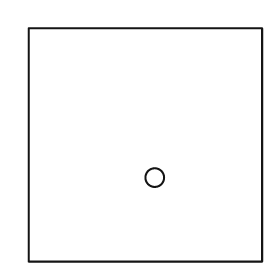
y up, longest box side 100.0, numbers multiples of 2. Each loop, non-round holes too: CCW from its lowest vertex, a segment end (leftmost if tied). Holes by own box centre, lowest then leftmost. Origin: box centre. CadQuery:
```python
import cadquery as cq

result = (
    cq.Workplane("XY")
    .moveTo(-50.0, -50.0)
    .lineTo(50.0, -50.0)
    .lineTo(50.0, 50.0)
    .lineTo(-50.0, 50.0)
    .close()
    .moveTo(4.0, -14.0)
    .circle(4.0)
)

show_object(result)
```